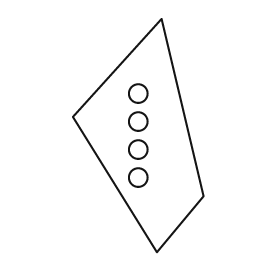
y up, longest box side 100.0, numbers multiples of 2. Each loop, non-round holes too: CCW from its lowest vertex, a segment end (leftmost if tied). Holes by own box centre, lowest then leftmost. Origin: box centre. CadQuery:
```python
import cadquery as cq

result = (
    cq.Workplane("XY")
    .moveTo(8.0, -50.0)
    .lineTo(28.0, -26.0)
    .lineTo(10.0, 50.0)
    .lineTo(-28.0, 8.0)
    .close()
    .moveTo(0.0, -18.0)
    .circle(4.0)
    .moveTo(0.0, -6.0)
    .circle(4.0)
    .moveTo(0.0, 6.0)
    .circle(4.0)
    .moveTo(0.0, 18.0)
    .circle(4.0)
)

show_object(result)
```